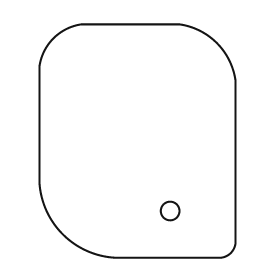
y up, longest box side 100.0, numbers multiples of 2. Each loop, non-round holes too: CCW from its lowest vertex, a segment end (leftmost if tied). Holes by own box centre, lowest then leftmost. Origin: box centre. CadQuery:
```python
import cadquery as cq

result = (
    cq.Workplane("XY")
    .moveTo(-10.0, -50.0)
    .lineTo(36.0, -50.0)
    .threePointArc((40.0, -48.0), (42.0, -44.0))
    .lineTo(42.0, 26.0)
    .threePointArc((34.0, 42.0), (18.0, 50.0))
    .lineTo(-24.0, 50.0)
    .threePointArc((-36.0, 44.0), (-42.0, 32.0))
    .lineTo(-42.0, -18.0)
    .threePointArc((-32.0, -40.0), (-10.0, -50.0))
    .close()
    .moveTo(14.0, -30.0)
    .circle(4.0)
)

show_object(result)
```